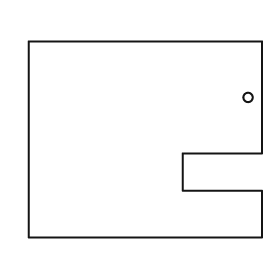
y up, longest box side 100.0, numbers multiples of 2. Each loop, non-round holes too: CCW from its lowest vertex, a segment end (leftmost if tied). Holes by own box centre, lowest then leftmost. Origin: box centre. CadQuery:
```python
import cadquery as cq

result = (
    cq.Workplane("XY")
    .moveTo(-50.0, -42.0)
    .lineTo(50.0, -42.0)
    .lineTo(50.0, -22.0)
    .lineTo(16.0, -22.0)
    .lineTo(16.0, -6.0)
    .lineTo(50.0, -6.0)
    .lineTo(50.0, 42.0)
    .lineTo(-50.0, 42.0)
    .close()
    .moveTo(44.0, 18.0)
    .circle(2.0)
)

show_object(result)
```